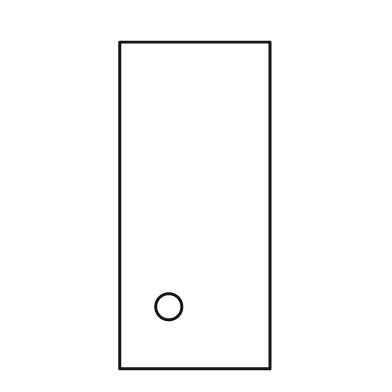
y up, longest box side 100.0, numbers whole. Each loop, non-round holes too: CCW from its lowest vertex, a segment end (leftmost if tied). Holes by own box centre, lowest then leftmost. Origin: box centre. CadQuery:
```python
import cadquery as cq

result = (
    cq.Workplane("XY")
    .moveTo(-23.0, -50.0)
    .lineTo(23.0, -50.0)
    .lineTo(23.0, 50.0)
    .lineTo(-23.0, 50.0)
    .close()
    .moveTo(-8.0, -31.0)
    .circle(4.0)
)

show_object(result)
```